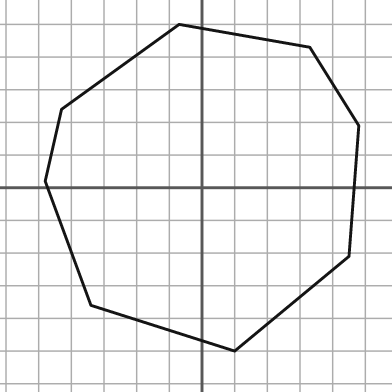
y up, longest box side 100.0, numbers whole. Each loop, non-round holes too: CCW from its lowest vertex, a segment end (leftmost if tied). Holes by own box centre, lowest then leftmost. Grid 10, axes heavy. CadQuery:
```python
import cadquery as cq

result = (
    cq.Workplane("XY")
    .moveTo(10.0, -50.0)
    .lineTo(45.0, -21.0)
    .lineTo(48.0, 19.0)
    .lineTo(33.0, 43.0)
    .lineTo(-7.0, 50.0)
    .lineTo(-43.0, 24.0)
    .lineTo(-48.0, 2.0)
    .lineTo(-34.0, -36.0)
    .close()
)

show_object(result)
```